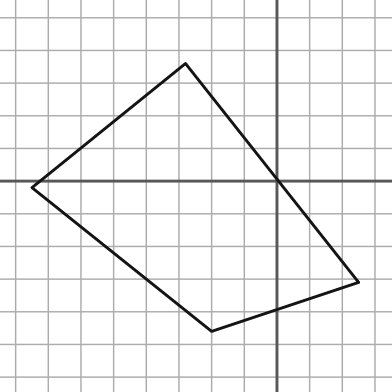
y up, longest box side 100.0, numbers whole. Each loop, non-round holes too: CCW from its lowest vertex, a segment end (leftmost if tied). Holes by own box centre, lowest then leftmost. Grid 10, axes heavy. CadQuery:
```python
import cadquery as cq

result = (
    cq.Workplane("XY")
    .moveTo(-20.0, -46.0)
    .lineTo(25.0, -31.0)
    .lineTo(-28.0, 36.0)
    .lineTo(-75.0, -2.0)
    .close()
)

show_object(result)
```